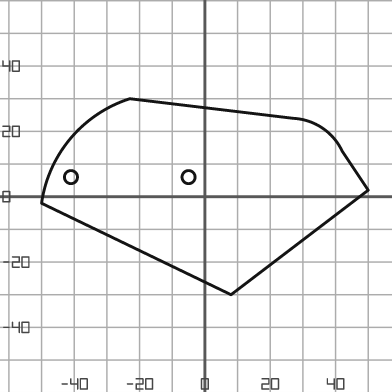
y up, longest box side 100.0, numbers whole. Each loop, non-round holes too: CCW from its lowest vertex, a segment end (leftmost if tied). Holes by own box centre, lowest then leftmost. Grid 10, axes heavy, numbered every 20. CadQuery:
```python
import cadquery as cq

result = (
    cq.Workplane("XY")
    .moveTo(8.0, -30.0)
    .lineTo(50.0, 2.0)
    .lineTo(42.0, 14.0)
    .threePointArc((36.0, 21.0), (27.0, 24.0))
    .lineTo(-23.0, 30.0)
    .threePointArc((-41.0, 18.0), (-50.0, -2.0))
    .close()
    .moveTo(-41.0, 6.0)
    .circle(2.0)
    .moveTo(-5.0, 6.0)
    .circle(2.0)
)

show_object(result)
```